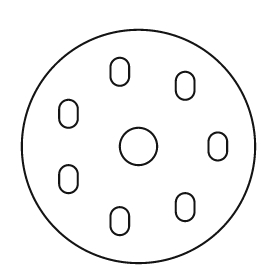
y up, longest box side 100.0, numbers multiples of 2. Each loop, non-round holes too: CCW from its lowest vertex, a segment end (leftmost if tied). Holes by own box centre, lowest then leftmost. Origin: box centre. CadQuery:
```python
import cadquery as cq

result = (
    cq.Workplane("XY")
    .moveTo(0.0, 0.0)
    .circle(50.0)
    .moveTo(-12.0, -34.0)
    .threePointArc((-8.0, -38.0), (-4.0, -34.0))
    .lineTo(-4.0, -30.0)
    .threePointArc((-8.0, -26.0), (-12.0, -30.0))
    .close()
    .moveTo(16.0, -28.0)
    .threePointArc((20.0, -32.0), (24.0, -28.0))
    .lineTo(24.0, -24.0)
    .threePointArc((20.0, -20.0), (16.0, -24.0))
    .close()
    .moveTo(-34.0, -16.0)
    .threePointArc((-30.0, -20.0), (-26.0, -16.0))
    .lineTo(-26.0, -12.0)
    .threePointArc((-30.0, -8.0), (-34.0, -12.0))
    .close()
    .moveTo(0.0, 0.0)
    .circle(8.0)
    .moveTo(30.0, -2.0)
    .threePointArc((34.0, -6.0), (38.0, -2.0))
    .lineTo(38.0, 2.0)
    .threePointArc((34.0, 6.0), (30.0, 2.0))
    .close()
    .moveTo(-34.0, 12.0)
    .threePointArc((-30.0, 8.0), (-26.0, 12.0))
    .lineTo(-26.0, 16.0)
    .threePointArc((-30.0, 20.0), (-34.0, 16.0))
    .close()
    .moveTo(16.0, 24.0)
    .threePointArc((20.0, 20.0), (24.0, 24.0))
    .lineTo(24.0, 28.0)
    .threePointArc((20.0, 32.0), (16.0, 28.0))
    .close()
    .moveTo(-12.0, 30.0)
    .threePointArc((-8.0, 26.0), (-4.0, 30.0))
    .lineTo(-4.0, 34.0)
    .threePointArc((-8.0, 38.0), (-12.0, 34.0))
    .close()
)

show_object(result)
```